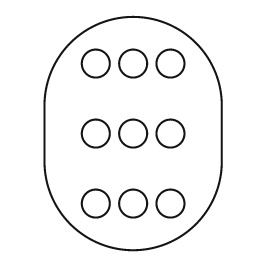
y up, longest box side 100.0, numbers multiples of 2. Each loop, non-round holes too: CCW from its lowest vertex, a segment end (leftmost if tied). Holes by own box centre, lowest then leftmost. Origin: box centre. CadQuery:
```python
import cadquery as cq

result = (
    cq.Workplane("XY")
    .moveTo(-38.0, -12.0)
    .threePointArc((0.0, -50.0), (38.0, -12.0))
    .lineTo(38.0, 12.0)
    .threePointArc((0.0, 50.0), (-38.0, 12.0))
    .close()
    .moveTo(-16.0, -30.0)
    .circle(6.0)
    .moveTo(0.0, -30.0)
    .circle(6.0)
    .moveTo(16.0, -30.0)
    .circle(6.0)
    .moveTo(-16.0, 0.0)
    .circle(6.0)
    .moveTo(0.0, 0.0)
    .circle(6.0)
    .moveTo(16.0, 0.0)
    .circle(6.0)
    .moveTo(-16.0, 30.0)
    .circle(6.0)
    .moveTo(0.0, 30.0)
    .circle(6.0)
    .moveTo(16.0, 30.0)
    .circle(6.0)
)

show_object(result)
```